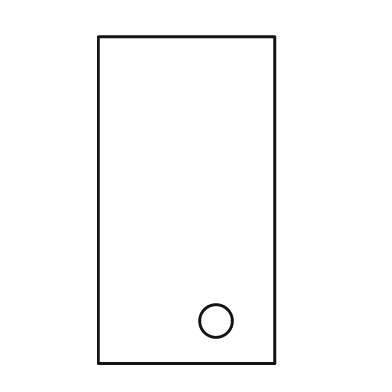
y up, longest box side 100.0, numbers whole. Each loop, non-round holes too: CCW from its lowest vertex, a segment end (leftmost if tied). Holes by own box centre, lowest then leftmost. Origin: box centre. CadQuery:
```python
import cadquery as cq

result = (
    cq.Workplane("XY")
    .moveTo(-27.0, -50.0)
    .lineTo(27.0, -50.0)
    .lineTo(27.0, 50.0)
    .lineTo(-27.0, 50.0)
    .close()
    .moveTo(9.0, -37.0)
    .circle(5.0)
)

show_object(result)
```